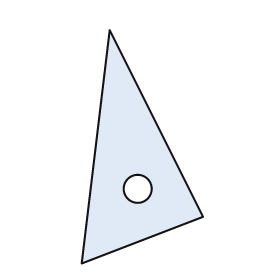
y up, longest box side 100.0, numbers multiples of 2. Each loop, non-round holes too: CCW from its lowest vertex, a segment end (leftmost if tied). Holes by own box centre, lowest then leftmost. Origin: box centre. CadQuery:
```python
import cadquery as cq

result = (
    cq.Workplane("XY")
    .moveTo(-26.0, -50.0)
    .lineTo(26.0, -30.0)
    .lineTo(-14.0, 50.0)
    .close()
    .moveTo(-2.0, -18.0)
    .circle(6.0)
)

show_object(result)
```